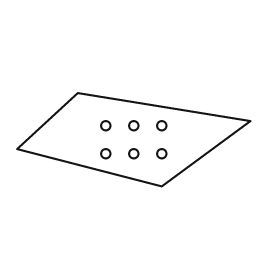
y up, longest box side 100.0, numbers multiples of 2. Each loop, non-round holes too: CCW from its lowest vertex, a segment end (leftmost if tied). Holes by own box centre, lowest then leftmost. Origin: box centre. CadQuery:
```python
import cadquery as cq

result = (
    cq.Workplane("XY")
    .moveTo(12.0, -20.0)
    .lineTo(50.0, 8.0)
    .lineTo(-24.0, 20.0)
    .lineTo(-50.0, -4.0)
    .close()
    .moveTo(-12.0, -6.0)
    .circle(2.0)
    .moveTo(0.0, -6.0)
    .circle(2.0)
    .moveTo(12.0, -6.0)
    .circle(2.0)
    .moveTo(-12.0, 6.0)
    .circle(2.0)
    .moveTo(0.0, 6.0)
    .circle(2.0)
    .moveTo(12.0, 6.0)
    .circle(2.0)
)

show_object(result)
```